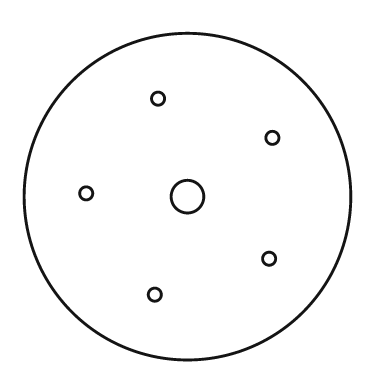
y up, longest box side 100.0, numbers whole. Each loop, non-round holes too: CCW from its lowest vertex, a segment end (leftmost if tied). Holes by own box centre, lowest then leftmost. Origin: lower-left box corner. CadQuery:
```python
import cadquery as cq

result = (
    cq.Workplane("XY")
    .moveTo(50.0, 50.0)
    .circle(50.0)
    .moveTo(40.0, 20.0)
    .circle(2.0)
    .moveTo(75.0, 31.0)
    .circle(2.0)
    .moveTo(50.0, 50.0)
    .circle(5.0)
    .moveTo(19.0, 51.0)
    .circle(2.0)
    .moveTo(76.0, 68.0)
    .circle(2.0)
    .moveTo(41.0, 80.0)
    .circle(2.0)
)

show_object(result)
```